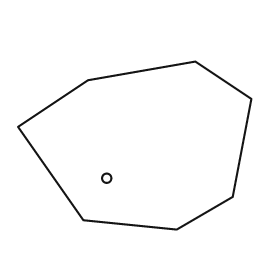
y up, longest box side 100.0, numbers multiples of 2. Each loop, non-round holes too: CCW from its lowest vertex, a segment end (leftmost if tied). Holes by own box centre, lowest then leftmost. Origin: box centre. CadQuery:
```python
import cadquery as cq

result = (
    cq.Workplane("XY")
    .moveTo(18.0, -36.0)
    .lineTo(42.0, -22.0)
    .lineTo(50.0, 20.0)
    .lineTo(26.0, 36.0)
    .lineTo(-20.0, 28.0)
    .lineTo(-50.0, 8.0)
    .lineTo(-22.0, -32.0)
    .close()
    .moveTo(-12.0, -14.0)
    .circle(2.0)
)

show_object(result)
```